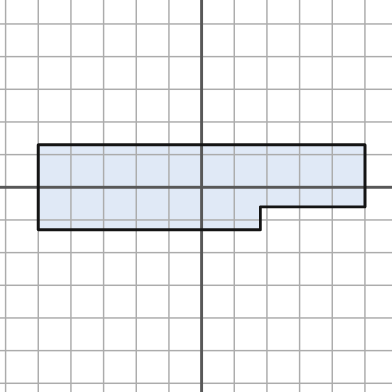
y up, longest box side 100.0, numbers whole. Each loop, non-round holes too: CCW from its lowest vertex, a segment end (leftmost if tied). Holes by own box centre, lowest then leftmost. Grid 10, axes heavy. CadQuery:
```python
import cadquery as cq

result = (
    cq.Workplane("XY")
    .moveTo(-50.0, -13.0)
    .lineTo(18.0, -13.0)
    .lineTo(18.0, -6.0)
    .lineTo(50.0, -6.0)
    .lineTo(50.0, 13.0)
    .lineTo(-50.0, 13.0)
    .close()
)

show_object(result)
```